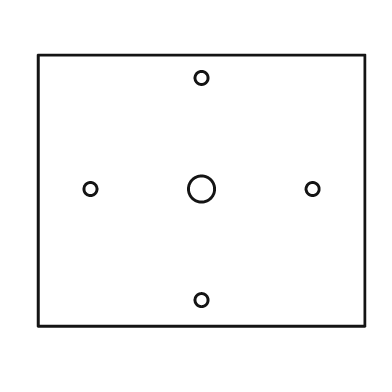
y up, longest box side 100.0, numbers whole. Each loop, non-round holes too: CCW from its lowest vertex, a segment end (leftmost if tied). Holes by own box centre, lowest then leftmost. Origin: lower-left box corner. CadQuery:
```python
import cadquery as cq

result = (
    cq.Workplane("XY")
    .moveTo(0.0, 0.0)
    .lineTo(100.0, 0.0)
    .lineTo(100.0, 83.0)
    .lineTo(0.0, 83.0)
    .close()
    .moveTo(50.0, 8.0)
    .circle(2.0)
    .moveTo(16.0, 42.0)
    .circle(2.0)
    .moveTo(50.0, 42.0)
    .circle(4.0)
    .moveTo(84.0, 42.0)
    .circle(2.0)
    .moveTo(50.0, 76.0)
    .circle(2.0)
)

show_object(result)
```